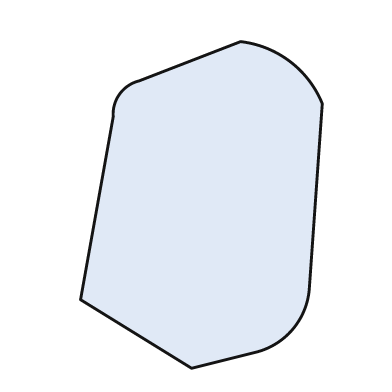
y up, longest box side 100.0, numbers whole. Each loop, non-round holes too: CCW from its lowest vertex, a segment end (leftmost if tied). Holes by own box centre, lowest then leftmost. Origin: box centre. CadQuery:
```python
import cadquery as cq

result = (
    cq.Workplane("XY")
    .moveTo(-3.0, -50.0)
    .lineTo(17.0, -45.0)
    .threePointArc((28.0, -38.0), (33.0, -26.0))
    .lineTo(37.0, 31.0)
    .threePointArc((27.0, 44.0), (12.0, 50.0))
    .lineTo(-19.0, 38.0)
    .threePointArc((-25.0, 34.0), (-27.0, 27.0))
    .lineTo(-37.0, -29.0)
    .close()
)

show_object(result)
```